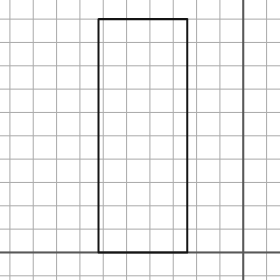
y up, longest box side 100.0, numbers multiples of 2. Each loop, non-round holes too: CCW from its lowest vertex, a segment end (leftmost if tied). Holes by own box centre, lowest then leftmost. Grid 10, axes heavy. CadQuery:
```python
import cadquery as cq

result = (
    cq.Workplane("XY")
    .moveTo(-62.0, 0.0)
    .lineTo(-24.0, 0.0)
    .lineTo(-24.0, 100.0)
    .lineTo(-62.0, 100.0)
    .close()
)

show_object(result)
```